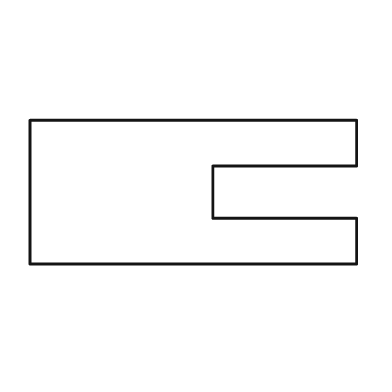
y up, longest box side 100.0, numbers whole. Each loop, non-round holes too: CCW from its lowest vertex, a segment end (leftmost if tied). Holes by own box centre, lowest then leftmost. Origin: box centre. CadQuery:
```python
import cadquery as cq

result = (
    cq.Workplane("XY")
    .moveTo(-50.0, -22.0)
    .lineTo(50.0, -22.0)
    .lineTo(50.0, -8.0)
    .lineTo(6.0, -8.0)
    .lineTo(6.0, 8.0)
    .lineTo(50.0, 8.0)
    .lineTo(50.0, 22.0)
    .lineTo(-50.0, 22.0)
    .close()
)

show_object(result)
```